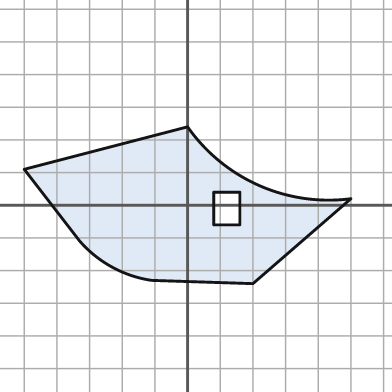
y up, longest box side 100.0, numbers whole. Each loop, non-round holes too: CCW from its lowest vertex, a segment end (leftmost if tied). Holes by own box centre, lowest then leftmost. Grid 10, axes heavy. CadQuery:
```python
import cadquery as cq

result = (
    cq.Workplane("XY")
    .moveTo(20.0, -24.0)
    .lineTo(50.0, 2.0)
    .threePointArc((22.0, 6.0), (0.0, 24.0))
    .lineTo(-50.0, 11.0)
    .lineTo(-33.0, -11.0)
    .threePointArc((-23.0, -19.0), (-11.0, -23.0))
    .close()
    .moveTo(8.0, -6.0)
    .lineTo(16.0, -6.0)
    .lineTo(16.0, 4.0)
    .lineTo(8.0, 4.0)
    .close()
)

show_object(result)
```